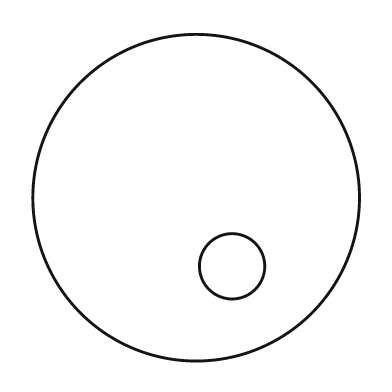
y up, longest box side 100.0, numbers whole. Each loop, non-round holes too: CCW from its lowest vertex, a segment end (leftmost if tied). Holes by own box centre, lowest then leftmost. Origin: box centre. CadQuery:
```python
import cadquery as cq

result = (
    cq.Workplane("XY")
    .moveTo(0.0, 0.0)
    .circle(50.0)
    .moveTo(11.0, -21.0)
    .circle(10.0)
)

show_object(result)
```